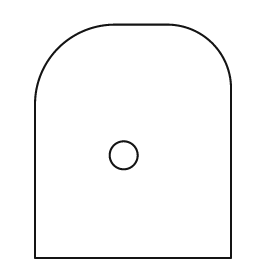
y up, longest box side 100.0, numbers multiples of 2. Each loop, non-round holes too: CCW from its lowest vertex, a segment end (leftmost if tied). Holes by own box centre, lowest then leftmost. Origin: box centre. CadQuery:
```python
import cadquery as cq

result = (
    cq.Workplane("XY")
    .moveTo(-42.0, -50.0)
    .lineTo(42.0, -50.0)
    .lineTo(42.0, 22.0)
    .threePointArc((34.0, 42.0), (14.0, 50.0))
    .lineTo(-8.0, 50.0)
    .threePointArc((-32.0, 40.0), (-42.0, 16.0))
    .close()
    .moveTo(-4.0, -6.0)
    .circle(6.0)
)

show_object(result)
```